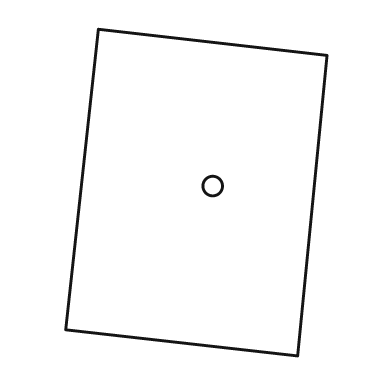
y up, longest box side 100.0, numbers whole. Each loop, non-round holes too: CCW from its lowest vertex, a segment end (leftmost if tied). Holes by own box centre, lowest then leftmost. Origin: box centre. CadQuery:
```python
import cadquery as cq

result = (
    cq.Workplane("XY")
    .moveTo(31.0, -50.0)
    .lineTo(40.0, 42.0)
    .lineTo(-30.0, 50.0)
    .lineTo(-40.0, -42.0)
    .close()
    .moveTo(5.0, 2.0)
    .circle(3.0)
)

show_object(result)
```